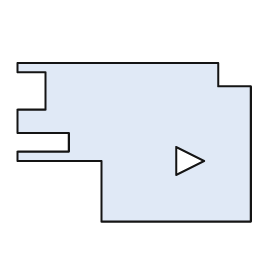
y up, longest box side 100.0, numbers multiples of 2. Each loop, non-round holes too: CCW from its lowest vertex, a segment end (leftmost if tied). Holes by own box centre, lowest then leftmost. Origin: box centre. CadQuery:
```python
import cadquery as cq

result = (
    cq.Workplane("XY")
    .moveTo(-14.0, -34.0)
    .lineTo(50.0, -34.0)
    .lineTo(50.0, 24.0)
    .lineTo(36.0, 24.0)
    .lineTo(36.0, 34.0)
    .lineTo(-50.0, 34.0)
    .lineTo(-50.0, 30.0)
    .lineTo(-38.0, 30.0)
    .lineTo(-38.0, 14.0)
    .lineTo(-50.0, 14.0)
    .lineTo(-50.0, 4.0)
    .lineTo(-28.0, 4.0)
    .lineTo(-28.0, -4.0)
    .lineTo(-50.0, -4.0)
    .lineTo(-50.0, -8.0)
    .lineTo(-14.0, -8.0)
    .close()
    .moveTo(18.0, -14.0)
    .lineTo(30.0, -8.0)
    .lineTo(18.0, -2.0)
    .close()
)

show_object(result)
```